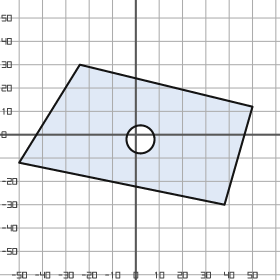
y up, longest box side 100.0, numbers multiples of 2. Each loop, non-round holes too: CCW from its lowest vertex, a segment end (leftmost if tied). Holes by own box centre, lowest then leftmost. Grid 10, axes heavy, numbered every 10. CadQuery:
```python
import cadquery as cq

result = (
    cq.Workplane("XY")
    .moveTo(38.0, -30.0)
    .lineTo(50.0, 12.0)
    .lineTo(-24.0, 30.0)
    .lineTo(-50.0, -12.0)
    .close()
    .moveTo(2.0, -2.0)
    .circle(6.0)
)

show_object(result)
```